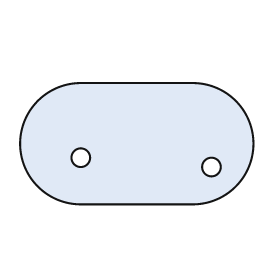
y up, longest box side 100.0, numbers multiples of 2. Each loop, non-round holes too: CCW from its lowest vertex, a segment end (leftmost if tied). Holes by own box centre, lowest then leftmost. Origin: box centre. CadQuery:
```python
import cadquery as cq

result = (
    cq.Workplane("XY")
    .moveTo(-24.0, -26.0)
    .lineTo(24.0, -26.0)
    .threePointArc((50.0, 0.0), (24.0, 26.0))
    .lineTo(-24.0, 26.0)
    .threePointArc((-50.0, 0.0), (-24.0, -26.0))
    .close()
    .moveTo(32.0, -10.0)
    .circle(4.0)
    .moveTo(-24.0, -6.0)
    .circle(4.0)
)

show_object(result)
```